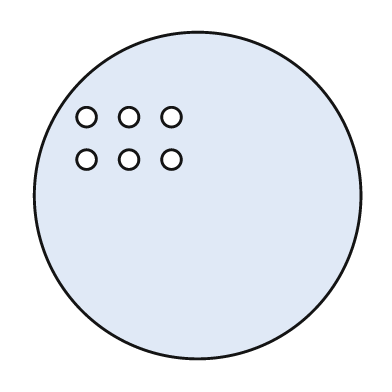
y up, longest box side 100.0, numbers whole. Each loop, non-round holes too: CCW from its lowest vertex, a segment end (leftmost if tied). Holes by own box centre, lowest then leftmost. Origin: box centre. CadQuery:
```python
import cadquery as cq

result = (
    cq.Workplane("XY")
    .moveTo(0.0, 0.0)
    .circle(50.0)
    .moveTo(-34.0, 11.0)
    .circle(3.0)
    .moveTo(-21.0, 11.0)
    .circle(3.0)
    .moveTo(-8.0, 11.0)
    .circle(3.0)
    .moveTo(-34.0, 24.0)
    .circle(3.0)
    .moveTo(-21.0, 24.0)
    .circle(3.0)
    .moveTo(-8.0, 24.0)
    .circle(3.0)
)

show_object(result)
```